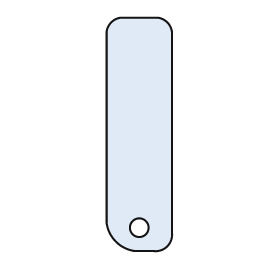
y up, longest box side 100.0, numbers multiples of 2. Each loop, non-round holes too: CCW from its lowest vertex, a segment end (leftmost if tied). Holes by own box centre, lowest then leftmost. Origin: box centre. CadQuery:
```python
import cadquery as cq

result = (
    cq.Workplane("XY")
    .moveTo(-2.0, -50.0)
    .lineTo(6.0, -50.0)
    .threePointArc((12.0, -48.0), (14.0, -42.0))
    .lineTo(14.0, 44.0)
    .threePointArc((12.0, 48.0), (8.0, 50.0))
    .lineTo(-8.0, 50.0)
    .threePointArc((-12.0, 48.0), (-14.0, 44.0))
    .lineTo(-14.0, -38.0)
    .threePointArc((-10.0, -46.0), (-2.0, -50.0))
    .close()
    .moveTo(0.0, -40.0)
    .circle(4.0)
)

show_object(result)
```